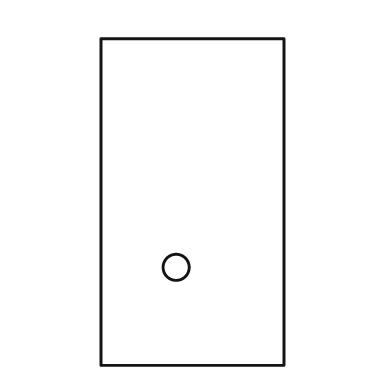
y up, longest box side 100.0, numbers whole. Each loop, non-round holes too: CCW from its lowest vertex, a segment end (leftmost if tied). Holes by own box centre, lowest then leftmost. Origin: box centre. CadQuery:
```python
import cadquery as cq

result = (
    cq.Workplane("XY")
    .moveTo(-28.0, -50.0)
    .lineTo(28.0, -50.0)
    .lineTo(28.0, 50.0)
    .lineTo(-28.0, 50.0)
    .close()
    .moveTo(-5.0, -20.0)
    .circle(4.0)
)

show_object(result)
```